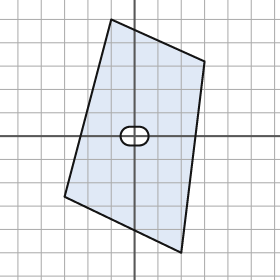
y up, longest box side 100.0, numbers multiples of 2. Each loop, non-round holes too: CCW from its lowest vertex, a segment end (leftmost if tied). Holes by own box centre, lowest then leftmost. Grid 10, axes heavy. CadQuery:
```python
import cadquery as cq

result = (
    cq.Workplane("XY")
    .moveTo(20.0, -50.0)
    .lineTo(30.0, 32.0)
    .lineTo(-10.0, 50.0)
    .lineTo(-30.0, -26.0)
    .close()
    .moveTo(-2.0, -4.0)
    .lineTo(2.0, -4.0)
    .threePointArc((6.0, 0.0), (2.0, 4.0))
    .lineTo(-2.0, 4.0)
    .threePointArc((-6.0, 0.0), (-2.0, -4.0))
    .close()
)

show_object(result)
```